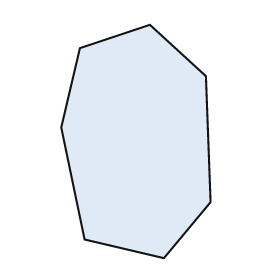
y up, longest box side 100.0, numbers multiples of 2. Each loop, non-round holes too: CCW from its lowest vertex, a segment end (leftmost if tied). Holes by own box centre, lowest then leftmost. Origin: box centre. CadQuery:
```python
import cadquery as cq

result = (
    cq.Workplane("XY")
    .moveTo(12.0, -50.0)
    .lineTo(32.0, -26.0)
    .lineTo(30.0, 28.0)
    .lineTo(6.0, 50.0)
    .lineTo(-24.0, 40.0)
    .lineTo(-32.0, 6.0)
    .lineTo(-22.0, -42.0)
    .close()
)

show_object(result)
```